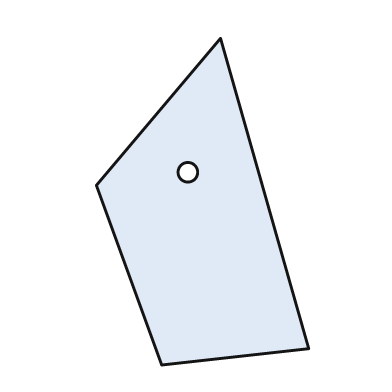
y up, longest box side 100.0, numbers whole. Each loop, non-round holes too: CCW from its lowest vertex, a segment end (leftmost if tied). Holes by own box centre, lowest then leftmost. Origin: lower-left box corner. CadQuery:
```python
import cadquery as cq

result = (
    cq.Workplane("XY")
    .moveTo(20.0, 0.0)
    .lineTo(65.0, 5.0)
    .lineTo(38.0, 100.0)
    .lineTo(0.0, 55.0)
    .close()
    .moveTo(28.0, 59.0)
    .circle(3.0)
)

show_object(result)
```